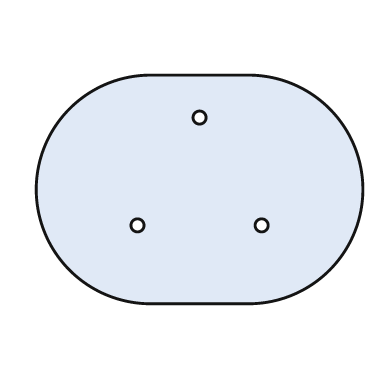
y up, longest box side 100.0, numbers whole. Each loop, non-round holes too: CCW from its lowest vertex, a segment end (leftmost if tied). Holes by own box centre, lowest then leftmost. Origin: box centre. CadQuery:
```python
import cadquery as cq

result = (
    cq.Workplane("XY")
    .moveTo(-15.0, -35.0)
    .lineTo(15.0, -35.0)
    .threePointArc((50.0, 0.0), (15.0, 35.0))
    .lineTo(-15.0, 35.0)
    .threePointArc((-50.0, 0.0), (-15.0, -35.0))
    .close()
    .moveTo(-19.0, -11.0)
    .circle(2.0)
    .moveTo(19.0, -11.0)
    .circle(2.0)
    .moveTo(0.0, 22.0)
    .circle(2.0)
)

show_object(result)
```